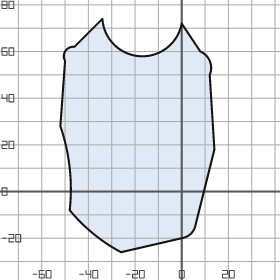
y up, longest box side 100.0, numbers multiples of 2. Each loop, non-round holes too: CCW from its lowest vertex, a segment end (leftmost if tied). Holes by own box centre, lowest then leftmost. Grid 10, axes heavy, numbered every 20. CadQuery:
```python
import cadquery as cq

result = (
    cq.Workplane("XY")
    .moveTo(-26.0, -26.0)
    .lineTo(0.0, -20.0)
    .threePointArc((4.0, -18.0), (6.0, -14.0))
    .lineTo(14.0, 18.0)
    .lineTo(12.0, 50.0)
    .threePointArc((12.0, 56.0), (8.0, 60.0))
    .lineTo(0.0, 72.0)
    .threePointArc((-18.0, 58.0), (-34.0, 74.0))
    .lineTo(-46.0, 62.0)
    .threePointArc((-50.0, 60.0), (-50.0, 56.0))
    .lineTo(-52.0, 28.0)
    .threePointArc((-48.0, 10.0), (-48.0, -8.0))
    .threePointArc((-38.0, -18.0), (-26.0, -26.0))
    .close()
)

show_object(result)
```